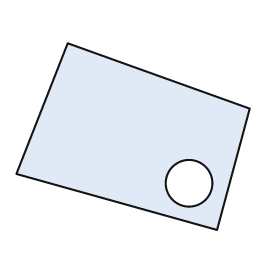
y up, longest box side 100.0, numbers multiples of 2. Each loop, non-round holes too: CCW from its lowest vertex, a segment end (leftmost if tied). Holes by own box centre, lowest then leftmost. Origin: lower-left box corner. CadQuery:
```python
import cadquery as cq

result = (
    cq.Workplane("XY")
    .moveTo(86.0, 0.0)
    .lineTo(100.0, 52.0)
    .lineTo(22.0, 80.0)
    .lineTo(0.0, 24.0)
    .close()
    .moveTo(74.0, 20.0)
    .circle(10.0)
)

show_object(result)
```